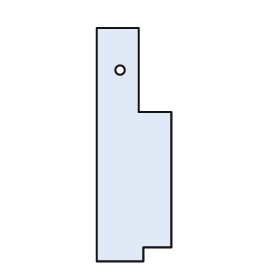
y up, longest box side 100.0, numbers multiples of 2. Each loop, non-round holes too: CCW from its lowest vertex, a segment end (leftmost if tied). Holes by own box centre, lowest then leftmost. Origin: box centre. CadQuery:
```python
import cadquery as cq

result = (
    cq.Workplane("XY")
    .moveTo(-16.0, -50.0)
    .lineTo(4.0, -50.0)
    .lineTo(4.0, -44.0)
    .lineTo(16.0, -44.0)
    .lineTo(16.0, 14.0)
    .lineTo(2.0, 14.0)
    .lineTo(2.0, 50.0)
    .lineTo(-16.0, 50.0)
    .close()
    .moveTo(-6.0, 32.0)
    .circle(2.0)
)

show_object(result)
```